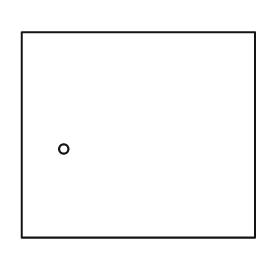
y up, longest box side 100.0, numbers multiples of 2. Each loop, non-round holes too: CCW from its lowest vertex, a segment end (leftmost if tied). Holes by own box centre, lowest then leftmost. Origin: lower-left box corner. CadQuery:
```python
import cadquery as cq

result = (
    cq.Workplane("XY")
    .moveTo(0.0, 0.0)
    .lineTo(100.0, 0.0)
    .lineTo(100.0, 88.0)
    .lineTo(0.0, 88.0)
    .close()
    .moveTo(18.0, 38.0)
    .circle(2.0)
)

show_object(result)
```